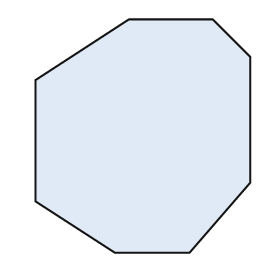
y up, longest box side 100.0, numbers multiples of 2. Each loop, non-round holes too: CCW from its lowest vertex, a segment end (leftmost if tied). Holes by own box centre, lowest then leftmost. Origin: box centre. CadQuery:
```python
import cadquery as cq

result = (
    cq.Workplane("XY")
    .moveTo(-12.0, -50.0)
    .lineTo(20.0, -50.0)
    .lineTo(46.0, -20.0)
    .lineTo(46.0, 34.0)
    .lineTo(30.0, 50.0)
    .lineTo(-6.0, 50.0)
    .lineTo(-46.0, 24.0)
    .lineTo(-46.0, -28.0)
    .close()
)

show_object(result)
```